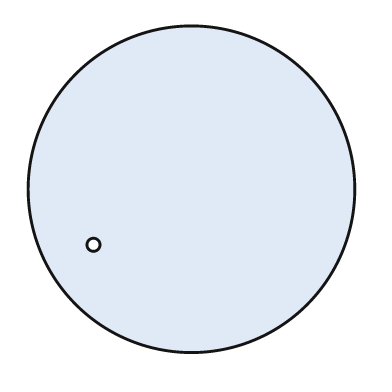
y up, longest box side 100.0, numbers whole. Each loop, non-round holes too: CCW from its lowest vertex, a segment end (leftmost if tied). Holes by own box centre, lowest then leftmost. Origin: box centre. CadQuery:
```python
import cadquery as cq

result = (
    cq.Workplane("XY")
    .moveTo(0.0, 0.0)
    .circle(50.0)
    .moveTo(-30.0, -17.0)
    .circle(2.0)
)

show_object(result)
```